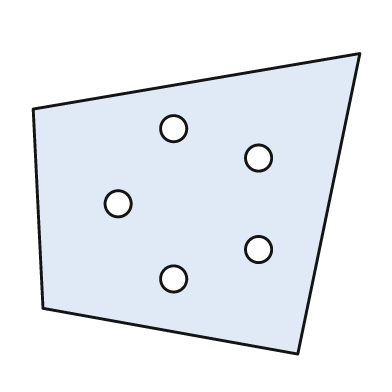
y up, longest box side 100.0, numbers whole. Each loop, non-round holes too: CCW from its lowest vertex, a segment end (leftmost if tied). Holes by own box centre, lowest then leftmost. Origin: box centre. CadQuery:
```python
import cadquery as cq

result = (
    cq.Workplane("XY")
    .moveTo(31.0, -46.0)
    .lineTo(50.0, 46.0)
    .lineTo(-50.0, 29.0)
    .lineTo(-47.0, -32.0)
    .close()
    .moveTo(-7.0, -23.0)
    .circle(4.0)
    .moveTo(19.0, -14.0)
    .circle(4.0)
    .moveTo(-24.0, 0.0)
    .circle(4.0)
    .moveTo(19.0, 14.0)
    .circle(4.0)
    .moveTo(-7.0, 23.0)
    .circle(4.0)
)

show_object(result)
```